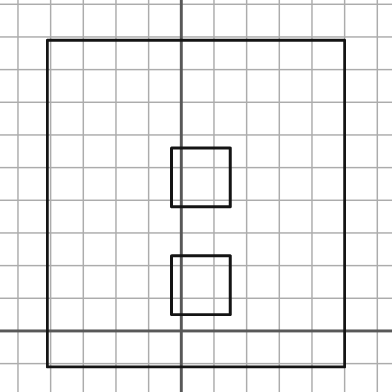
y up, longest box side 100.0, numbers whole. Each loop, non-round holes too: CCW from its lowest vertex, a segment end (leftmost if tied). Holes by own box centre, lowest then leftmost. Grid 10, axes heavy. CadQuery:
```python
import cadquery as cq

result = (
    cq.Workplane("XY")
    .moveTo(-41.0, -11.0)
    .lineTo(50.0, -11.0)
    .lineTo(50.0, 89.0)
    .lineTo(-41.0, 89.0)
    .close()
    .moveTo(-3.0, 5.0)
    .lineTo(15.0, 5.0)
    .lineTo(15.0, 23.0)
    .lineTo(-3.0, 23.0)
    .close()
    .moveTo(-3.0, 38.0)
    .lineTo(15.0, 38.0)
    .lineTo(15.0, 56.0)
    .lineTo(-3.0, 56.0)
    .close()
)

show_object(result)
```